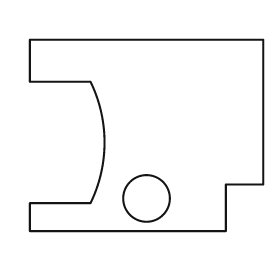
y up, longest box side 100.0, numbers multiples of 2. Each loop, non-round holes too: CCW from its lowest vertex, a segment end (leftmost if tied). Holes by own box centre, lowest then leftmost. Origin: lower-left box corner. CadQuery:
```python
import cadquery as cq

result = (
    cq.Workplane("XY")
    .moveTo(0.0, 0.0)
    .lineTo(84.0, 0.0)
    .lineTo(84.0, 20.0)
    .lineTo(100.0, 20.0)
    .lineTo(100.0, 82.0)
    .lineTo(0.0, 82.0)
    .lineTo(0.0, 64.0)
    .lineTo(26.0, 64.0)
    .threePointArc((32.0, 38.0), (26.0, 12.0))
    .lineTo(0.0, 12.0)
    .close()
    .moveTo(50.0, 14.0)
    .circle(10.0)
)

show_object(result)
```